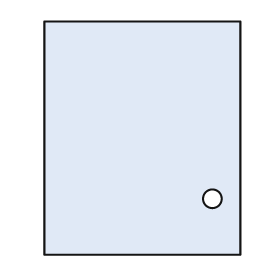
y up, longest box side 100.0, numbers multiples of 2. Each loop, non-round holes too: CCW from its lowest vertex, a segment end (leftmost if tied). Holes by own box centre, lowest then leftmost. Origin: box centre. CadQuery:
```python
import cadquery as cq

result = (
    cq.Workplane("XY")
    .moveTo(-42.0, -50.0)
    .lineTo(42.0, -50.0)
    .lineTo(42.0, 50.0)
    .lineTo(-42.0, 50.0)
    .close()
    .moveTo(30.0, -26.0)
    .circle(4.0)
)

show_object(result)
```